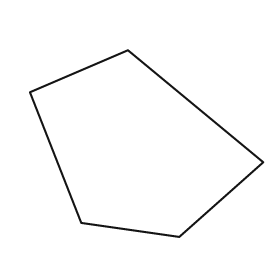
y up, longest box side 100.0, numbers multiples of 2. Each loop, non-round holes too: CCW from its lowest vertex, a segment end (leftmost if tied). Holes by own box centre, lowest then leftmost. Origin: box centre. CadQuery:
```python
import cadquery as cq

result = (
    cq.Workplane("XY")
    .moveTo(14.0, -40.0)
    .lineTo(50.0, -8.0)
    .lineTo(-8.0, 40.0)
    .lineTo(-50.0, 22.0)
    .lineTo(-28.0, -34.0)
    .close()
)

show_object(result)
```